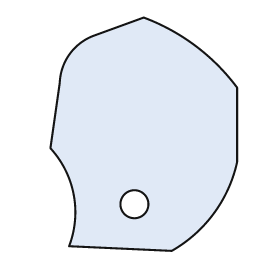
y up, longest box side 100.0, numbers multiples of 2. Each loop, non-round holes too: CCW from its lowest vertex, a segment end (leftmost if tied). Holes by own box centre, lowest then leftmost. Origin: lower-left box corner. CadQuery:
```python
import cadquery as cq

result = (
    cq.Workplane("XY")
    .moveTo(52.0, 0.0)
    .threePointArc((70.0, 16.0), (80.0, 38.0))
    .lineTo(80.0, 70.0)
    .threePointArc((62.0, 88.0), (40.0, 100.0))
    .lineTo(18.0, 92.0)
    .threePointArc((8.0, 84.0), (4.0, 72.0))
    .lineTo(0.0, 44.0)
    .threePointArc((10.0, 24.0), (8.0, 2.0))
    .close()
    .moveTo(36.0, 20.0)
    .circle(6.0)
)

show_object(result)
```